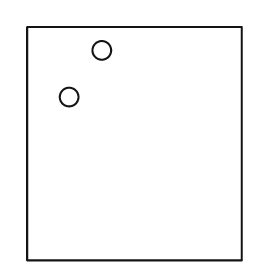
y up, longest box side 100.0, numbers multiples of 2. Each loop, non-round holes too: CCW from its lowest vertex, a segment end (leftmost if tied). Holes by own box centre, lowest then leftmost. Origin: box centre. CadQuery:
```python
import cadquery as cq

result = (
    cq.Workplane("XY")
    .moveTo(-46.0, -50.0)
    .lineTo(46.0, -50.0)
    .lineTo(46.0, 50.0)
    .lineTo(-46.0, 50.0)
    .close()
    .moveTo(-28.0, 20.0)
    .circle(4.0)
    .moveTo(-14.0, 40.0)
    .circle(4.0)
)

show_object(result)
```